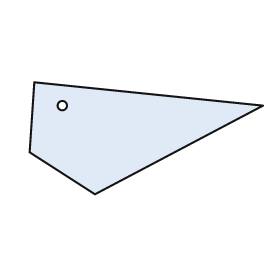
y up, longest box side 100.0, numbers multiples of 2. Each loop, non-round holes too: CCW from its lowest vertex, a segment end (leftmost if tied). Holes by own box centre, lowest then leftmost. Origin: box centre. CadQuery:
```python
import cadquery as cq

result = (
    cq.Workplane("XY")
    .moveTo(-22.0, -24.0)
    .lineTo(50.0, 14.0)
    .lineTo(-48.0, 24.0)
    .lineTo(-50.0, -6.0)
    .close()
    .moveTo(-36.0, 14.0)
    .circle(2.0)
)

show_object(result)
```